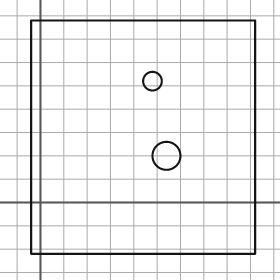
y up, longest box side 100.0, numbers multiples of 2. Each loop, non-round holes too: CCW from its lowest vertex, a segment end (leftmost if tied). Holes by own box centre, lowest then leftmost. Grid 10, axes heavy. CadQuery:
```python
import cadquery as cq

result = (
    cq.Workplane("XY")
    .moveTo(-4.0, -22.0)
    .lineTo(92.0, -22.0)
    .lineTo(92.0, 78.0)
    .lineTo(-4.0, 78.0)
    .close()
    .moveTo(54.0, 20.0)
    .circle(6.0)
    .moveTo(48.0, 52.0)
    .circle(4.0)
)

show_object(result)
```